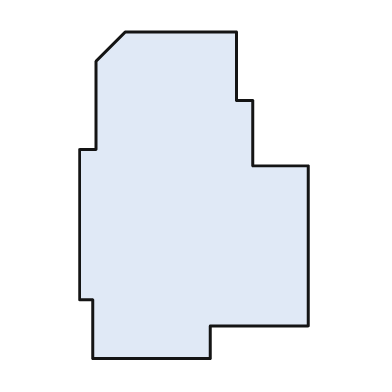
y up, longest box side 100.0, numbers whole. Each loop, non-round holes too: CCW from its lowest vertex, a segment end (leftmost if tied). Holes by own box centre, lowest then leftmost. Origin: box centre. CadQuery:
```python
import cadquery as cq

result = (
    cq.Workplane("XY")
    .moveTo(-31.0, -50.0)
    .lineTo(5.0, -50.0)
    .lineTo(5.0, -40.0)
    .lineTo(35.0, -40.0)
    .lineTo(35.0, 9.0)
    .lineTo(18.0, 9.0)
    .lineTo(18.0, 29.0)
    .lineTo(13.0, 29.0)
    .lineTo(13.0, 50.0)
    .lineTo(-21.0, 50.0)
    .lineTo(-30.0, 41.0)
    .lineTo(-30.0, 14.0)
    .lineTo(-35.0, 14.0)
    .lineTo(-35.0, -32.0)
    .lineTo(-31.0, -32.0)
    .close()
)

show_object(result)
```